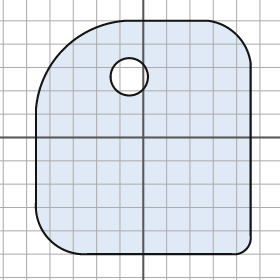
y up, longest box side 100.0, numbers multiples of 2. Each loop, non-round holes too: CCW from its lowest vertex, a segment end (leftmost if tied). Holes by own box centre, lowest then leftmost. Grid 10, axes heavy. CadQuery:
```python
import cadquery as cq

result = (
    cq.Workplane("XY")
    .moveTo(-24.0, -50.0)
    .lineTo(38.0, -50.0)
    .threePointArc((44.0, -48.0), (46.0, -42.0))
    .lineTo(46.0, 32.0)
    .threePointArc((40.0, 44.0), (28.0, 50.0))
    .lineTo(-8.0, 50.0)
    .threePointArc((-34.0, 38.0), (-46.0, 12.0))
    .lineTo(-46.0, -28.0)
    .threePointArc((-40.0, -44.0), (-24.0, -50.0))
    .close()
    .moveTo(-6.0, 26.0)
    .circle(8.0)
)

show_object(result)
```